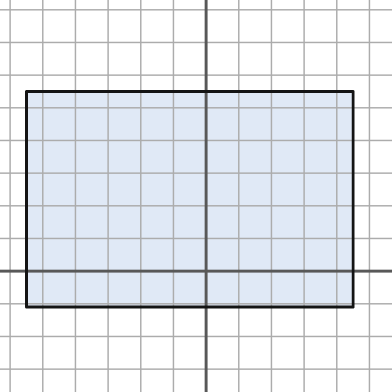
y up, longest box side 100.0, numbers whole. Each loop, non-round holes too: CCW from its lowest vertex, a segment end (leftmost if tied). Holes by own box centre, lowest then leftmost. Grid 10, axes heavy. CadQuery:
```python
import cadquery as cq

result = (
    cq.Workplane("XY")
    .moveTo(-55.0, -11.0)
    .lineTo(45.0, -11.0)
    .lineTo(45.0, 55.0)
    .lineTo(-55.0, 55.0)
    .close()
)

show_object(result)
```